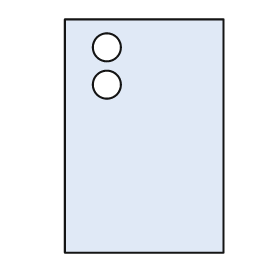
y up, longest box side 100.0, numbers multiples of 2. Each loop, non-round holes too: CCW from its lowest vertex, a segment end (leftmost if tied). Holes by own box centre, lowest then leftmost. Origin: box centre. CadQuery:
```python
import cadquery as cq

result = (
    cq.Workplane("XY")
    .moveTo(-34.0, -50.0)
    .lineTo(34.0, -50.0)
    .lineTo(34.0, 50.0)
    .lineTo(-34.0, 50.0)
    .close()
    .moveTo(-16.0, 22.0)
    .circle(6.0)
    .moveTo(-16.0, 38.0)
    .circle(6.0)
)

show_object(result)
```